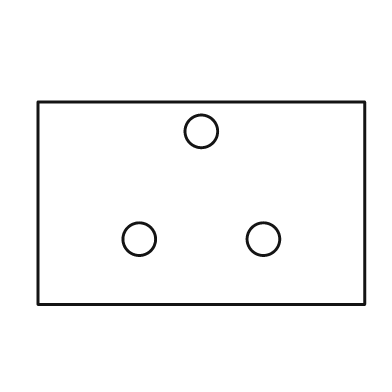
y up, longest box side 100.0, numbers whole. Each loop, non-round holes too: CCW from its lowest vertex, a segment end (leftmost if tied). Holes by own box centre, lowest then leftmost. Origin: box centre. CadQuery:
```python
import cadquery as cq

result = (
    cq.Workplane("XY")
    .moveTo(-50.0, -31.0)
    .lineTo(50.0, -31.0)
    .lineTo(50.0, 31.0)
    .lineTo(-50.0, 31.0)
    .close()
    .moveTo(-19.0, -11.0)
    .circle(5.0)
    .moveTo(19.0, -11.0)
    .circle(5.0)
    .moveTo(0.0, 22.0)
    .circle(5.0)
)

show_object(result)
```